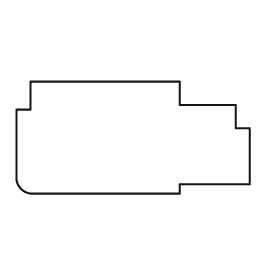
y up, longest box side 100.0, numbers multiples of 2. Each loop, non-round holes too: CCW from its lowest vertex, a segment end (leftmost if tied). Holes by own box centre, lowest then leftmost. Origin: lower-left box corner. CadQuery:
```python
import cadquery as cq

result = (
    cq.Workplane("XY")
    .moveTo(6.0, 0.0)
    .lineTo(70.0, 0.0)
    .lineTo(70.0, 4.0)
    .lineTo(100.0, 4.0)
    .lineTo(100.0, 28.0)
    .lineTo(94.0, 28.0)
    .lineTo(94.0, 38.0)
    .lineTo(70.0, 38.0)
    .lineTo(70.0, 48.0)
    .lineTo(6.0, 48.0)
    .lineTo(6.0, 36.0)
    .lineTo(0.0, 36.0)
    .lineTo(0.0, 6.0)
    .threePointArc((2.0, 2.0), (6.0, 0.0))
    .close()
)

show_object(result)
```